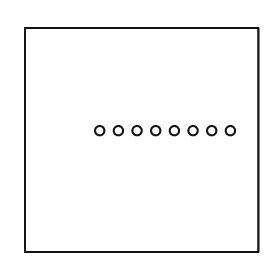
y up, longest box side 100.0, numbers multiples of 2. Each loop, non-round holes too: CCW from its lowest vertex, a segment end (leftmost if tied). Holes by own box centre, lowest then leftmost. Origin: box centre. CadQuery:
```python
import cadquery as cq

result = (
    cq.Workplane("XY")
    .moveTo(-50.0, -48.0)
    .lineTo(50.0, -48.0)
    .lineTo(50.0, 48.0)
    .lineTo(-50.0, 48.0)
    .close()
    .moveTo(-18.0, 4.0)
    .circle(2.0)
    .moveTo(-10.0, 4.0)
    .circle(2.0)
    .moveTo(-2.0, 4.0)
    .circle(2.0)
    .moveTo(6.0, 4.0)
    .circle(2.0)
    .moveTo(14.0, 4.0)
    .circle(2.0)
    .moveTo(22.0, 4.0)
    .circle(2.0)
    .moveTo(30.0, 4.0)
    .circle(2.0)
    .moveTo(38.0, 4.0)
    .circle(2.0)
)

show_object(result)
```